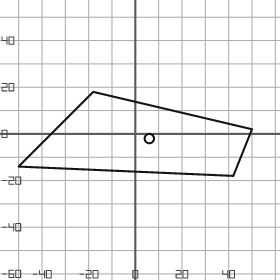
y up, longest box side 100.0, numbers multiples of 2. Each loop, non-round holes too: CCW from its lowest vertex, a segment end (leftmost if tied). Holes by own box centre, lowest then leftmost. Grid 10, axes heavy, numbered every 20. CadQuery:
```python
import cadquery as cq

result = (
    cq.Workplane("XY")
    .moveTo(42.0, -18.0)
    .lineTo(50.0, 2.0)
    .lineTo(-18.0, 18.0)
    .lineTo(-50.0, -14.0)
    .close()
    .moveTo(6.0, -2.0)
    .circle(2.0)
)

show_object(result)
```